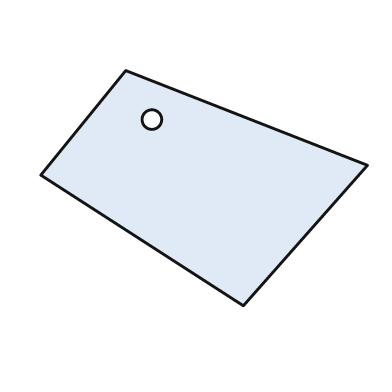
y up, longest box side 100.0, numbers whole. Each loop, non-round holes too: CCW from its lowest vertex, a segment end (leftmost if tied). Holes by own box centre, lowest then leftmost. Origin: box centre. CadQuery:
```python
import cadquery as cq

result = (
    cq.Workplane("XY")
    .moveTo(12.0, -36.0)
    .lineTo(50.0, 7.0)
    .lineTo(-24.0, 36.0)
    .lineTo(-50.0, 4.0)
    .close()
    .moveTo(-16.0, 21.0)
    .circle(3.0)
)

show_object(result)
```